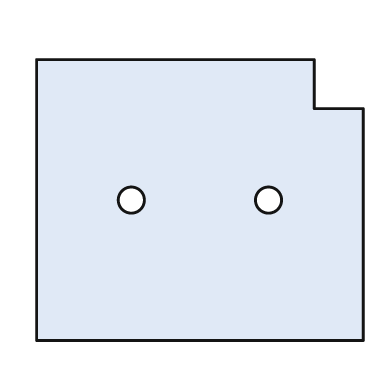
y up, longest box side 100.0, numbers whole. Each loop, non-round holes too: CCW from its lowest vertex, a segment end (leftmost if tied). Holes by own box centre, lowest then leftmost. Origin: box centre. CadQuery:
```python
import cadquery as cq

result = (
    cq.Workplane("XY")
    .moveTo(-50.0, -43.0)
    .lineTo(50.0, -43.0)
    .lineTo(50.0, 28.0)
    .lineTo(35.0, 28.0)
    .lineTo(35.0, 43.0)
    .lineTo(-50.0, 43.0)
    .close()
    .moveTo(-21.0, 0.0)
    .circle(4.0)
    .moveTo(21.0, 0.0)
    .circle(4.0)
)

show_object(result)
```